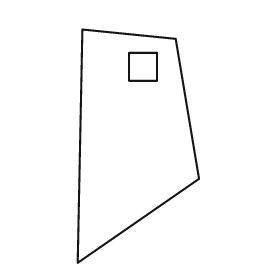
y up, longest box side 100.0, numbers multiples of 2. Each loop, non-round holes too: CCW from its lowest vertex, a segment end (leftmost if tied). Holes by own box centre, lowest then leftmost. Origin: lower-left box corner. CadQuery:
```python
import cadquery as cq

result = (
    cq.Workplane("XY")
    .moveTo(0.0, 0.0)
    .lineTo(52.0, 36.0)
    .lineTo(42.0, 96.0)
    .lineTo(2.0, 100.0)
    .close()
    .moveTo(22.0, 78.0)
    .lineTo(34.0, 78.0)
    .lineTo(34.0, 90.0)
    .lineTo(22.0, 90.0)
    .close()
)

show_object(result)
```